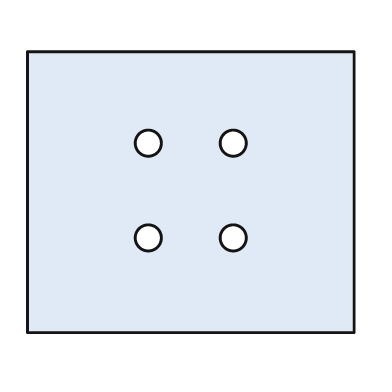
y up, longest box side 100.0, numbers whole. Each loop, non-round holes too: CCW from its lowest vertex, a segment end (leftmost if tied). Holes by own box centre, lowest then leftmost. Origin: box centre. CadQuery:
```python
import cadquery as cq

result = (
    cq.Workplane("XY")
    .moveTo(-50.0, -43.0)
    .lineTo(50.0, -43.0)
    .lineTo(50.0, 43.0)
    .lineTo(-50.0, 43.0)
    .close()
    .moveTo(-13.0, -14.0)
    .circle(4.0)
    .moveTo(13.0, -14.0)
    .circle(4.0)
    .moveTo(-13.0, 15.0)
    .circle(4.0)
    .moveTo(13.0, 15.0)
    .circle(4.0)
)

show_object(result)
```